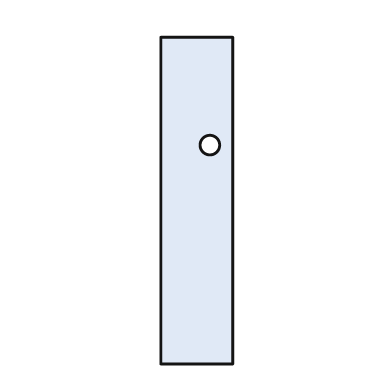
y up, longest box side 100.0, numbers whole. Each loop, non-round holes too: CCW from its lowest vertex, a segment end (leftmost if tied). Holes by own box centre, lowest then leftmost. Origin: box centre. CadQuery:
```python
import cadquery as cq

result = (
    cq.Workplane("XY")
    .moveTo(-11.0, -50.0)
    .lineTo(11.0, -50.0)
    .lineTo(11.0, 50.0)
    .lineTo(-11.0, 50.0)
    .close()
    .moveTo(4.0, 17.0)
    .circle(3.0)
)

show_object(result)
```